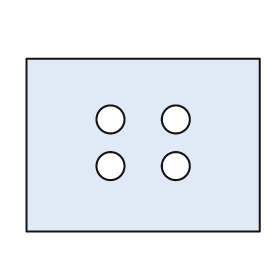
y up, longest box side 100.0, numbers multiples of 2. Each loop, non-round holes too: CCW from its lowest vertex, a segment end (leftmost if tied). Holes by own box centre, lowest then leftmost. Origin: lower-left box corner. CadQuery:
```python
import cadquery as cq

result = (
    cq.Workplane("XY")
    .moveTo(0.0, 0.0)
    .lineTo(100.0, 0.0)
    .lineTo(100.0, 74.0)
    .lineTo(0.0, 74.0)
    .close()
    .moveTo(36.0, 28.0)
    .circle(6.0)
    .moveTo(64.0, 28.0)
    .circle(6.0)
    .moveTo(36.0, 48.0)
    .circle(6.0)
    .moveTo(64.0, 48.0)
    .circle(6.0)
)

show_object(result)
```